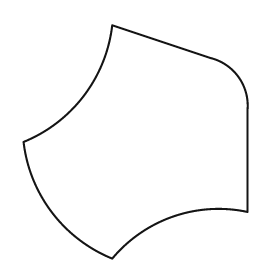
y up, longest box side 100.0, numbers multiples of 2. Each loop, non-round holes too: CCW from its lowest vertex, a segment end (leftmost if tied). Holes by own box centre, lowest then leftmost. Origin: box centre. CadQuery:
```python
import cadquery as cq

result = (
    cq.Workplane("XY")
    .moveTo(-10.0, -50.0)
    .threePointArc((16.0, -32.0), (48.0, -30.0))
    .lineTo(48.0, 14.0)
    .threePointArc((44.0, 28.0), (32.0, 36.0))
    .lineTo(-10.0, 50.0)
    .threePointArc((-22.0, 20.0), (-48.0, 0.0))
    .threePointArc((-36.0, -30.0), (-10.0, -50.0))
    .close()
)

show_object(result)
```